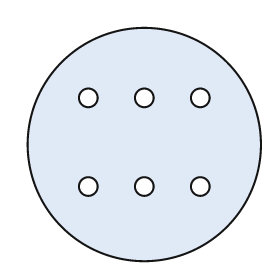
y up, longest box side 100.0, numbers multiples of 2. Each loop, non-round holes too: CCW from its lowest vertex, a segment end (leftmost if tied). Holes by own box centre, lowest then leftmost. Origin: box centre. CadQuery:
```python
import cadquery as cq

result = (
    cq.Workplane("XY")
    .moveTo(0.0, 0.0)
    .circle(50.0)
    .moveTo(-24.0, -18.0)
    .circle(4.0)
    .moveTo(0.0, -18.0)
    .circle(4.0)
    .moveTo(24.0, -18.0)
    .circle(4.0)
    .moveTo(-24.0, 20.0)
    .circle(4.0)
    .moveTo(0.0, 20.0)
    .circle(4.0)
    .moveTo(24.0, 20.0)
    .circle(4.0)
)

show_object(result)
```